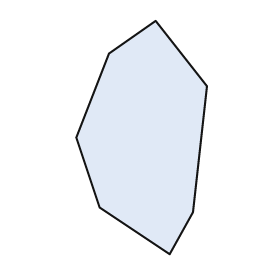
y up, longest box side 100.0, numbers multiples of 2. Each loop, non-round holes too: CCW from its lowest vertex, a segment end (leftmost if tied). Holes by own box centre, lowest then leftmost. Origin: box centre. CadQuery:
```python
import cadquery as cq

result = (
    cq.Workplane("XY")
    .moveTo(12.0, -50.0)
    .lineTo(22.0, -32.0)
    .lineTo(28.0, 22.0)
    .lineTo(6.0, 50.0)
    .lineTo(-14.0, 36.0)
    .lineTo(-28.0, 0.0)
    .lineTo(-18.0, -30.0)
    .close()
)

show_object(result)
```